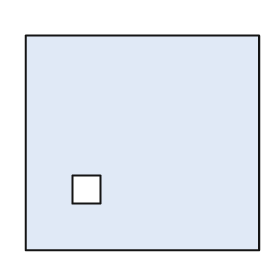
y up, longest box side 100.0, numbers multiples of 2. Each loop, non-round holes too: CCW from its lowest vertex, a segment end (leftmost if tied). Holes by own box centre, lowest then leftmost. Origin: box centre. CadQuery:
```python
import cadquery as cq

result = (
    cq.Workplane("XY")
    .moveTo(-50.0, -46.0)
    .lineTo(50.0, -46.0)
    .lineTo(50.0, 46.0)
    .lineTo(-50.0, 46.0)
    .close()
    .moveTo(-30.0, -26.0)
    .lineTo(-18.0, -26.0)
    .lineTo(-18.0, -14.0)
    .lineTo(-30.0, -14.0)
    .close()
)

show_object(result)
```